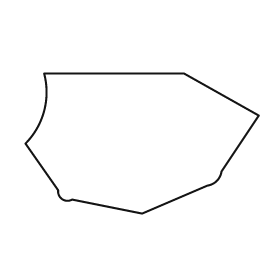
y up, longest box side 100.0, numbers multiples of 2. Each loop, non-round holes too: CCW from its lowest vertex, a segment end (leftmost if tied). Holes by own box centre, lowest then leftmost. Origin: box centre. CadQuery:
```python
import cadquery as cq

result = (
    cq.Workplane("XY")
    .moveTo(0.0, -30.0)
    .lineTo(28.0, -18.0)
    .threePointArc((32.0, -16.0), (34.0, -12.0))
    .lineTo(50.0, 12.0)
    .lineTo(18.0, 30.0)
    .lineTo(-42.0, 30.0)
    .threePointArc((-42.0, 14.0), (-50.0, 0.0))
    .lineTo(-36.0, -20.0)
    .threePointArc((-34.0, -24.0), (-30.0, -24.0))
    .close()
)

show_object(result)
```